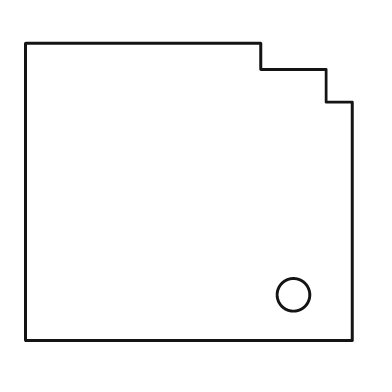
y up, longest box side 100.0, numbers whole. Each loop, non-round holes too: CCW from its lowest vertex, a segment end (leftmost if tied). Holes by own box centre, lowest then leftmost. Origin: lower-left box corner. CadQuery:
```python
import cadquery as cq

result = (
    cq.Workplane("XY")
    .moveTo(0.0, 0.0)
    .lineTo(100.0, 0.0)
    .lineTo(100.0, 73.0)
    .lineTo(92.0, 73.0)
    .lineTo(92.0, 83.0)
    .lineTo(72.0, 83.0)
    .lineTo(72.0, 91.0)
    .lineTo(0.0, 91.0)
    .close()
    .moveTo(82.0, 14.0)
    .circle(5.0)
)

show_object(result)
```